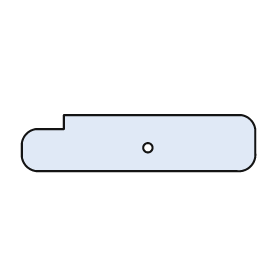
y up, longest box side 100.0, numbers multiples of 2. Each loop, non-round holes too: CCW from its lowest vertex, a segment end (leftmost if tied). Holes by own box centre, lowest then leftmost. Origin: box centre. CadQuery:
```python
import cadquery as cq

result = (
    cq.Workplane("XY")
    .moveTo(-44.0, -12.0)
    .lineTo(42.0, -12.0)
    .threePointArc((48.0, -10.0), (50.0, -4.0))
    .lineTo(50.0, 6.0)
    .threePointArc((48.0, 10.0), (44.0, 12.0))
    .lineTo(-32.0, 12.0)
    .lineTo(-32.0, 6.0)
    .lineTo(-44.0, 6.0)
    .threePointArc((-48.0, 4.0), (-50.0, 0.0))
    .lineTo(-50.0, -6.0)
    .threePointArc((-48.0, -10.0), (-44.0, -12.0))
    .close()
    .moveTo(4.0, -2.0)
    .circle(2.0)
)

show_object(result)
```